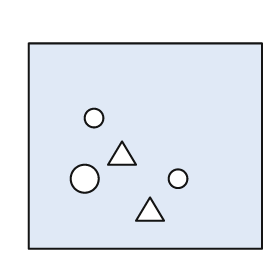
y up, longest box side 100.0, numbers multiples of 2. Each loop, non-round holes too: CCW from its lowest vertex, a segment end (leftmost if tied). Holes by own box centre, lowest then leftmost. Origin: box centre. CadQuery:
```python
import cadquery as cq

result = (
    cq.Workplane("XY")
    .moveTo(-50.0, -44.0)
    .lineTo(50.0, -44.0)
    .lineTo(50.0, 44.0)
    .lineTo(-50.0, 44.0)
    .close()
    .moveTo(-4.0, -32.0)
    .lineTo(8.0, -32.0)
    .lineTo(2.0, -22.0)
    .close()
    .moveTo(-26.0, -14.0)
    .circle(6.0)
    .moveTo(14.0, -14.0)
    .circle(4.0)
    .moveTo(-16.0, -8.0)
    .lineTo(-4.0, -8.0)
    .lineTo(-10.0, 2.0)
    .close()
    .moveTo(-22.0, 12.0)
    .circle(4.0)
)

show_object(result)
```